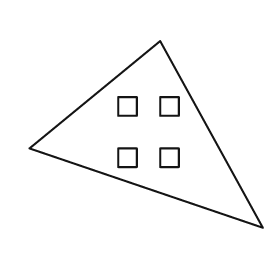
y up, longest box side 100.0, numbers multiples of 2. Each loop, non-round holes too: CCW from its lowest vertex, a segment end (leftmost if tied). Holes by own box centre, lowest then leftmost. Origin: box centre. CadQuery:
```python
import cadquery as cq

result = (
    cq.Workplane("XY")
    .moveTo(50.0, -40.0)
    .lineTo(6.0, 40.0)
    .lineTo(-50.0, -6.0)
    .close()
    .moveTo(-12.0, -14.0)
    .lineTo(-4.0, -14.0)
    .lineTo(-4.0, -6.0)
    .lineTo(-12.0, -6.0)
    .close()
    .moveTo(6.0, -14.0)
    .lineTo(14.0, -14.0)
    .lineTo(14.0, -6.0)
    .lineTo(6.0, -6.0)
    .close()
    .moveTo(-12.0, 8.0)
    .lineTo(-4.0, 8.0)
    .lineTo(-4.0, 16.0)
    .lineTo(-12.0, 16.0)
    .close()
    .moveTo(6.0, 8.0)
    .lineTo(14.0, 8.0)
    .lineTo(14.0, 16.0)
    .lineTo(6.0, 16.0)
    .close()
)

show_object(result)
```